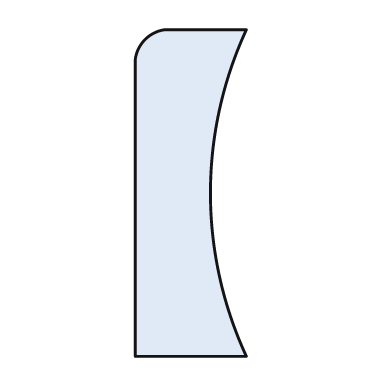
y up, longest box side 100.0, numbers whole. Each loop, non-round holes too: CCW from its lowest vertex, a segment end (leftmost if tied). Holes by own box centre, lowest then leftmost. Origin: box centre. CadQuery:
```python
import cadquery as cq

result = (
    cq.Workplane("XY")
    .moveTo(-17.0, -50.0)
    .lineTo(17.0, -50.0)
    .threePointArc((6.0, 0.0), (17.0, 50.0))
    .lineTo(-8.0, 50.0)
    .threePointArc((-14.0, 47.0), (-17.0, 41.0))
    .close()
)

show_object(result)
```